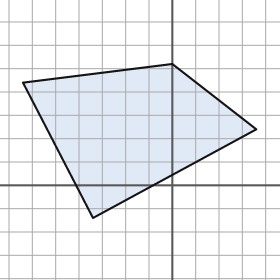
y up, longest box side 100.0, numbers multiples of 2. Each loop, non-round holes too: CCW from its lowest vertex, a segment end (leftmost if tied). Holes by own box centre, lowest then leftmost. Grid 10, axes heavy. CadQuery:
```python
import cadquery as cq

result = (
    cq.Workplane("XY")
    .moveTo(-34.0, -14.0)
    .lineTo(36.0, 24.0)
    .lineTo(0.0, 52.0)
    .lineTo(-64.0, 44.0)
    .close()
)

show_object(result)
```